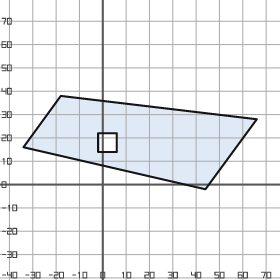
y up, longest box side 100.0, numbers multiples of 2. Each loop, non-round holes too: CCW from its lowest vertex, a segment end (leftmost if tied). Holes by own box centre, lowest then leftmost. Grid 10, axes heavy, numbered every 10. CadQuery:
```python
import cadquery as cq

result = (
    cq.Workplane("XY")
    .moveTo(44.0, -2.0)
    .lineTo(66.0, 28.0)
    .lineTo(-18.0, 38.0)
    .lineTo(-34.0, 16.0)
    .close()
    .moveTo(-2.0, 14.0)
    .lineTo(6.0, 14.0)
    .lineTo(6.0, 22.0)
    .lineTo(-2.0, 22.0)
    .close()
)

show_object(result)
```